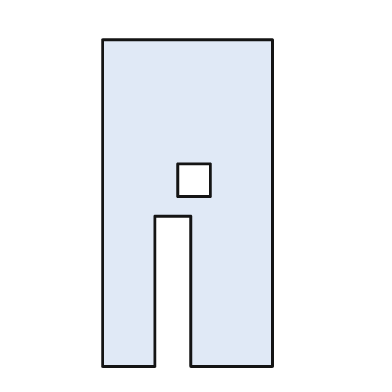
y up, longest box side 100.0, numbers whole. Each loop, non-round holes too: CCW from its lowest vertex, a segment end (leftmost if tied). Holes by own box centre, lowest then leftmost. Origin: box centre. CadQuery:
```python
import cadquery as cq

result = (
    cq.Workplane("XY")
    .moveTo(-26.0, -50.0)
    .lineTo(-10.0, -50.0)
    .lineTo(-10.0, -4.0)
    .lineTo(1.0, -4.0)
    .lineTo(1.0, -50.0)
    .lineTo(26.0, -50.0)
    .lineTo(26.0, 50.0)
    .lineTo(-26.0, 50.0)
    .close()
    .moveTo(-3.0, 2.0)
    .lineTo(7.0, 2.0)
    .lineTo(7.0, 12.0)
    .lineTo(-3.0, 12.0)
    .close()
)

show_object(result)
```